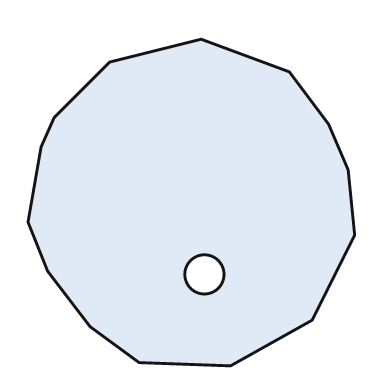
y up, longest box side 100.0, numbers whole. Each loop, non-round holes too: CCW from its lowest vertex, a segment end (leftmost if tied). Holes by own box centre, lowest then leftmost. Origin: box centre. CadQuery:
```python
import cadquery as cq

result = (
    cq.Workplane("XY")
    .moveTo(12.0, -50.0)
    .lineTo(37.0, -36.0)
    .lineTo(50.0, -10.0)
    .lineTo(48.0, 10.0)
    .lineTo(42.0, 24.0)
    .lineTo(30.0, 40.0)
    .lineTo(3.0, 50.0)
    .lineTo(-25.0, 43.0)
    .lineTo(-42.0, 26.0)
    .lineTo(-46.0, 17.0)
    .lineTo(-50.0, -6.0)
    .lineTo(-44.0, -21.0)
    .lineTo(-31.0, -38.0)
    .lineTo(-16.0, -49.0)
    .close()
    .moveTo(4.0, -22.0)
    .circle(6.0)
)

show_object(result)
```